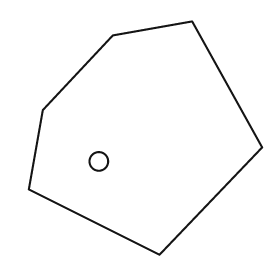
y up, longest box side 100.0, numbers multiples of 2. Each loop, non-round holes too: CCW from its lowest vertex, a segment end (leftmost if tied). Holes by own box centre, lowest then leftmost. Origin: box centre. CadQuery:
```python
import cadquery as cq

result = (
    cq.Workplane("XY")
    .moveTo(6.0, -50.0)
    .lineTo(50.0, -4.0)
    .lineTo(20.0, 50.0)
    .lineTo(-14.0, 44.0)
    .lineTo(-44.0, 12.0)
    .lineTo(-50.0, -22.0)
    .close()
    .moveTo(-20.0, -10.0)
    .circle(4.0)
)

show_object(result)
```